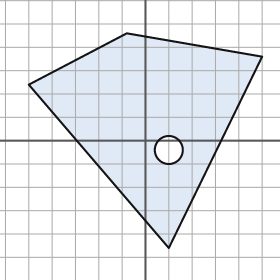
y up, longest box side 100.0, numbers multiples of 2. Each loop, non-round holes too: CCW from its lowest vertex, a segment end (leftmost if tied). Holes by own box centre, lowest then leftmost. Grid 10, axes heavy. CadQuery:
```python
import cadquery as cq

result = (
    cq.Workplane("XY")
    .moveTo(10.0, -46.0)
    .lineTo(50.0, 36.0)
    .lineTo(-8.0, 46.0)
    .lineTo(-50.0, 24.0)
    .close()
    .moveTo(10.0, -4.0)
    .circle(6.0)
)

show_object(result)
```